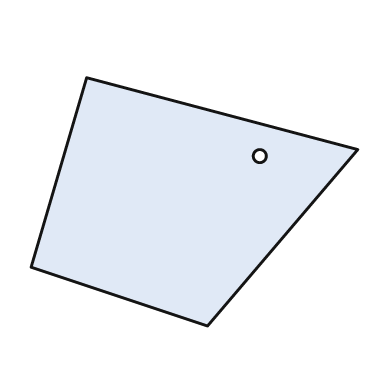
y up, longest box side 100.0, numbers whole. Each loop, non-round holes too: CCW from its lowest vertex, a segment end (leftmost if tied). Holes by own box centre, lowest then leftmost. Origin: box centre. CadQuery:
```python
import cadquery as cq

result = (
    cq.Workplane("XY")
    .moveTo(4.0, -38.0)
    .lineTo(50.0, 16.0)
    .lineTo(-33.0, 38.0)
    .lineTo(-50.0, -20.0)
    .close()
    .moveTo(20.0, 14.0)
    .circle(2.0)
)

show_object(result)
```